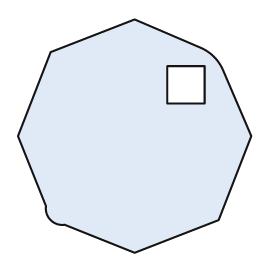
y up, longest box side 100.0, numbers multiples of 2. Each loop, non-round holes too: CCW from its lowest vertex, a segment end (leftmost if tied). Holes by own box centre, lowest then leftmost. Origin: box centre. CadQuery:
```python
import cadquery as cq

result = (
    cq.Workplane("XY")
    .moveTo(0.0, -50.0)
    .lineTo(36.0, -36.0)
    .lineTo(50.0, 0.0)
    .lineTo(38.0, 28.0)
    .threePointArc((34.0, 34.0), (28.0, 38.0))
    .lineTo(0.0, 50.0)
    .lineTo(-36.0, 36.0)
    .lineTo(-50.0, 0.0)
    .lineTo(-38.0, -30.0)
    .threePointArc((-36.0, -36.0), (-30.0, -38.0))
    .close()
    .moveTo(14.0, 14.0)
    .lineTo(30.0, 14.0)
    .lineTo(30.0, 30.0)
    .lineTo(14.0, 30.0)
    .close()
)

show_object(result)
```